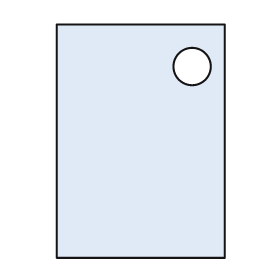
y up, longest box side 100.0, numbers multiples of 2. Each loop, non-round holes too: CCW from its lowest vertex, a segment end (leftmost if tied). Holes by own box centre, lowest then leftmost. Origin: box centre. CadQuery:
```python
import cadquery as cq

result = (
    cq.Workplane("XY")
    .moveTo(-36.0, -50.0)
    .lineTo(36.0, -50.0)
    .lineTo(36.0, 50.0)
    .lineTo(-36.0, 50.0)
    .close()
    .moveTo(22.0, 32.0)
    .circle(8.0)
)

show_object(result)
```